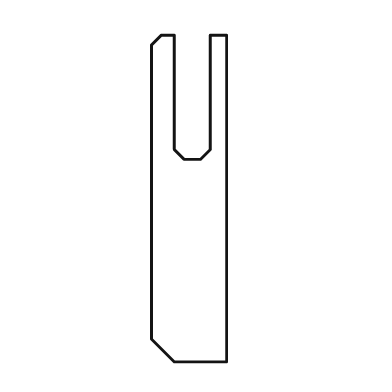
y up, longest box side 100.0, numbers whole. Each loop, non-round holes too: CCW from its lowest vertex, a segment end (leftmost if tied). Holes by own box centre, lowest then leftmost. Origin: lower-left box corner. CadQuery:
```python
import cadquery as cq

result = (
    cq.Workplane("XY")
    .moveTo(7.0, 0.0)
    .lineTo(23.0, 0.0)
    .lineTo(23.0, 100.0)
    .lineTo(18.0, 100.0)
    .lineTo(18.0, 65.0)
    .lineTo(15.0, 62.0)
    .lineTo(10.0, 62.0)
    .lineTo(7.0, 65.0)
    .lineTo(7.0, 100.0)
    .lineTo(3.0, 100.0)
    .lineTo(0.0, 97.0)
    .lineTo(0.0, 7.0)
    .close()
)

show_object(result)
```